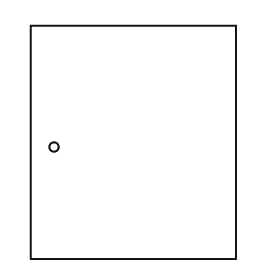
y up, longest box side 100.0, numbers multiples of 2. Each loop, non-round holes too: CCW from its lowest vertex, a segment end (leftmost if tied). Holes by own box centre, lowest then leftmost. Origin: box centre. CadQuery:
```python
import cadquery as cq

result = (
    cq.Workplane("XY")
    .moveTo(-44.0, -50.0)
    .lineTo(44.0, -50.0)
    .lineTo(44.0, 50.0)
    .lineTo(-44.0, 50.0)
    .close()
    .moveTo(-34.0, -2.0)
    .circle(2.0)
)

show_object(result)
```